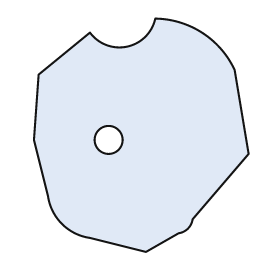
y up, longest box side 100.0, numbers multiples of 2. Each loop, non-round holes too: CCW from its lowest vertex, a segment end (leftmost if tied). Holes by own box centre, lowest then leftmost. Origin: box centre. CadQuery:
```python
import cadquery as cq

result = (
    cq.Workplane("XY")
    .moveTo(2.0, -50.0)
    .lineTo(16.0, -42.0)
    .threePointArc((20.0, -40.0), (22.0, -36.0))
    .lineTo(46.0, -8.0)
    .lineTo(40.0, 28.0)
    .threePointArc((26.0, 44.0), (6.0, 50.0))
    .threePointArc((-6.0, 38.0), (-22.0, 44.0))
    .lineTo(-44.0, 26.0)
    .lineTo(-46.0, -2.0)
    .lineTo(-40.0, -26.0)
    .threePointArc((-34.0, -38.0), (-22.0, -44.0))
    .close()
    .moveTo(-14.0, -2.0)
    .circle(6.0)
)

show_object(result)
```